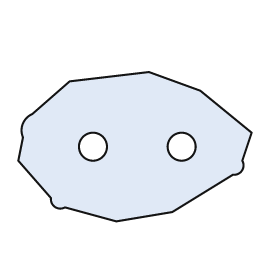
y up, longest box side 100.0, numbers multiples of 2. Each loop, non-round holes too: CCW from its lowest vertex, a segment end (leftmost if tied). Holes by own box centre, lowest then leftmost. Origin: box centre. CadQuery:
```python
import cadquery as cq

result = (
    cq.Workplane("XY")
    .moveTo(-8.0, -32.0)
    .lineTo(16.0, -28.0)
    .lineTo(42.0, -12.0)
    .threePointArc((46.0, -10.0), (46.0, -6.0))
    .lineTo(50.0, 6.0)
    .lineTo(28.0, 24.0)
    .lineTo(6.0, 32.0)
    .lineTo(-28.0, 28.0)
    .lineTo(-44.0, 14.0)
    .threePointArc((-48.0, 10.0), (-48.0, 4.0))
    .lineTo(-50.0, -6.0)
    .lineTo(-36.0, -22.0)
    .threePointArc((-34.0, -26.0), (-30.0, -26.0))
    .close()
    .moveTo(-18.0, 0.0)
    .circle(6.0)
    .moveTo(20.0, 0.0)
    .circle(6.0)
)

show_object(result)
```